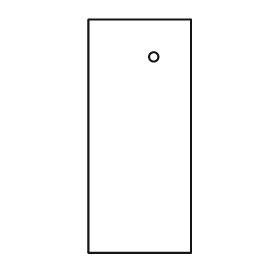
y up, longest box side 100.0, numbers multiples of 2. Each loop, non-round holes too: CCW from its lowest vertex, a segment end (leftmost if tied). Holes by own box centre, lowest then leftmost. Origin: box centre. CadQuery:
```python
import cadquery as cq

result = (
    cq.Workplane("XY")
    .moveTo(-22.0, -50.0)
    .lineTo(22.0, -50.0)
    .lineTo(22.0, 50.0)
    .lineTo(-22.0, 50.0)
    .close()
    .moveTo(6.0, 34.0)
    .circle(2.0)
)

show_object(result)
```